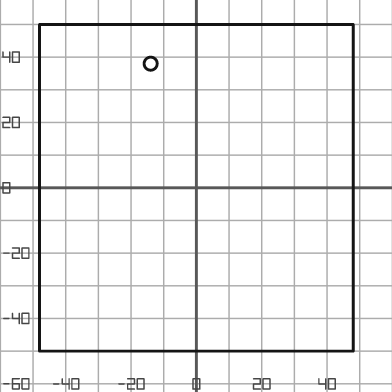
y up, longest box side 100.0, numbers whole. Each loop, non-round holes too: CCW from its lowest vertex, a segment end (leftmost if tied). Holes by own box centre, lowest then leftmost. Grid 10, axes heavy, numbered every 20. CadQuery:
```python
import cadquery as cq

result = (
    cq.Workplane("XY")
    .moveTo(-48.0, -50.0)
    .lineTo(48.0, -50.0)
    .lineTo(48.0, 50.0)
    .lineTo(-48.0, 50.0)
    .close()
    .moveTo(-14.0, 38.0)
    .circle(2.0)
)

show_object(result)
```